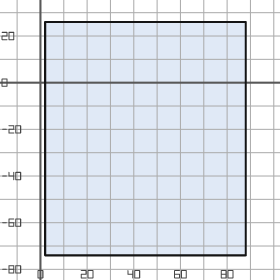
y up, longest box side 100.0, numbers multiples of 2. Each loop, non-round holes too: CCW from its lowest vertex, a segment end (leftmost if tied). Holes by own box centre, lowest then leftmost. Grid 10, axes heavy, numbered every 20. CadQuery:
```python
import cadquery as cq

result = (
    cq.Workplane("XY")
    .moveTo(2.0, -74.0)
    .lineTo(88.0, -74.0)
    .lineTo(88.0, 26.0)
    .lineTo(2.0, 26.0)
    .close()
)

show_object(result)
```